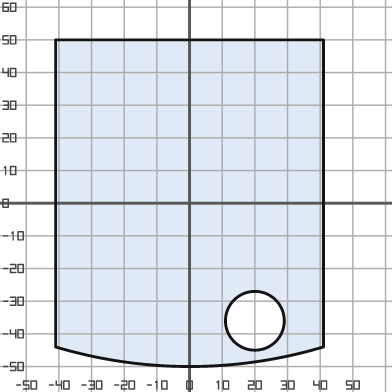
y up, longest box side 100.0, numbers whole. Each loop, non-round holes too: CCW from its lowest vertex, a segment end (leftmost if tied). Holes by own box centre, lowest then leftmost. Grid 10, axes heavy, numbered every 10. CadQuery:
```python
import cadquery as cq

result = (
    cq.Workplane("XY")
    .moveTo(-41.0, -44.0)
    .threePointArc((0.0, -50.0), (41.0, -44.0))
    .lineTo(41.0, 50.0)
    .lineTo(-41.0, 50.0)
    .close()
    .moveTo(20.0, -36.0)
    .circle(9.0)
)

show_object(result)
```